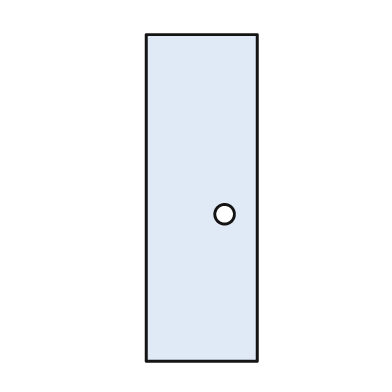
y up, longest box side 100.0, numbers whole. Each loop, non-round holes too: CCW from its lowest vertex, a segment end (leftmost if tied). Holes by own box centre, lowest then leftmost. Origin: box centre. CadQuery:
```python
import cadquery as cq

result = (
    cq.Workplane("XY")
    .moveTo(-17.0, -50.0)
    .lineTo(17.0, -50.0)
    .lineTo(17.0, 50.0)
    .lineTo(-17.0, 50.0)
    .close()
    .moveTo(7.0, -5.0)
    .circle(3.0)
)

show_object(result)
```